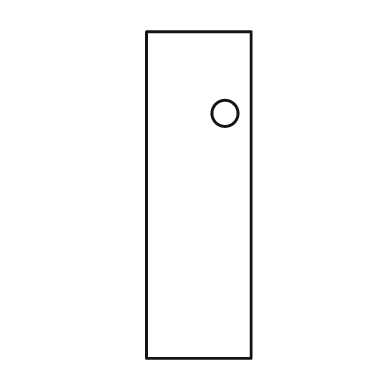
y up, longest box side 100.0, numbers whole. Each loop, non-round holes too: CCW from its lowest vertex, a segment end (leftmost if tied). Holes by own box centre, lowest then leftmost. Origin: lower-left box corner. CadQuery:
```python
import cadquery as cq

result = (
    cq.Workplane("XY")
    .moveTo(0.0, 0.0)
    .lineTo(32.0, 0.0)
    .lineTo(32.0, 100.0)
    .lineTo(0.0, 100.0)
    .close()
    .moveTo(24.0, 75.0)
    .circle(4.0)
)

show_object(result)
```